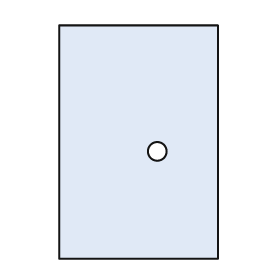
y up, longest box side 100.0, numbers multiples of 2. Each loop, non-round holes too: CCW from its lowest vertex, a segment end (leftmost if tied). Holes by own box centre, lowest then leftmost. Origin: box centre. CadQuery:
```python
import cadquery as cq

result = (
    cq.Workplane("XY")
    .moveTo(-34.0, -50.0)
    .lineTo(34.0, -50.0)
    .lineTo(34.0, 50.0)
    .lineTo(-34.0, 50.0)
    .close()
    .moveTo(8.0, -4.0)
    .circle(4.0)
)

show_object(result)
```